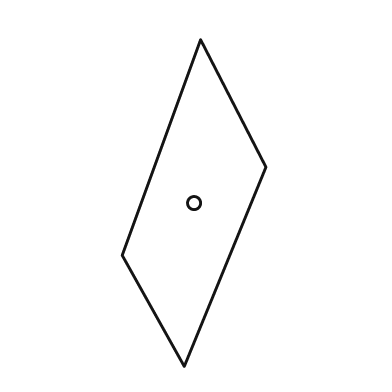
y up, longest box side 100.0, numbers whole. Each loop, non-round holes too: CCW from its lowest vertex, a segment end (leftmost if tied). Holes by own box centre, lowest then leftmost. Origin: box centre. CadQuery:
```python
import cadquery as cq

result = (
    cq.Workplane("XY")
    .moveTo(-3.0, -50.0)
    .lineTo(22.0, 11.0)
    .lineTo(2.0, 50.0)
    .lineTo(-22.0, -16.0)
    .close()
    .moveTo(0.0, 0.0)
    .circle(2.0)
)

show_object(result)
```